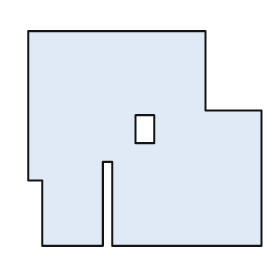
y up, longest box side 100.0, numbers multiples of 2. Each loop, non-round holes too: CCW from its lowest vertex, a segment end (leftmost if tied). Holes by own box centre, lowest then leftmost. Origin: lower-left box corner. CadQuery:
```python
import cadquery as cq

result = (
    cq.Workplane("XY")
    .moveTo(6.0, 0.0)
    .lineTo(32.0, 0.0)
    .lineTo(32.0, 36.0)
    .lineTo(36.0, 36.0)
    .lineTo(36.0, 0.0)
    .lineTo(100.0, 0.0)
    .lineTo(100.0, 58.0)
    .lineTo(76.0, 58.0)
    .lineTo(76.0, 92.0)
    .lineTo(0.0, 92.0)
    .lineTo(0.0, 28.0)
    .lineTo(6.0, 28.0)
    .close()
    .moveTo(46.0, 44.0)
    .lineTo(54.0, 44.0)
    .lineTo(54.0, 56.0)
    .lineTo(46.0, 56.0)
    .close()
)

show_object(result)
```